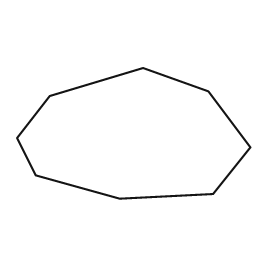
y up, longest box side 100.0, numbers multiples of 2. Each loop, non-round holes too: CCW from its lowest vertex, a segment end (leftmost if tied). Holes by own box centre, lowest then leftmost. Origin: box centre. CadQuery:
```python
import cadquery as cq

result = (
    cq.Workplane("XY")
    .moveTo(-6.0, -28.0)
    .lineTo(34.0, -26.0)
    .lineTo(50.0, -6.0)
    .lineTo(32.0, 18.0)
    .lineTo(4.0, 28.0)
    .lineTo(-36.0, 16.0)
    .lineTo(-50.0, -2.0)
    .lineTo(-42.0, -18.0)
    .close()
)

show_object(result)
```